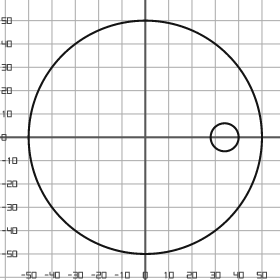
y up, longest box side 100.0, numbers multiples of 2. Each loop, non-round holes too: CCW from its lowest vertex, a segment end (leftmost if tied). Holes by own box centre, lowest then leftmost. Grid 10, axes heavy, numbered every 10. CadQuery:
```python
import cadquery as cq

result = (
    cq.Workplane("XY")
    .moveTo(0.0, 0.0)
    .circle(50.0)
    .moveTo(34.0, 0.0)
    .circle(6.0)
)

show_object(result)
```